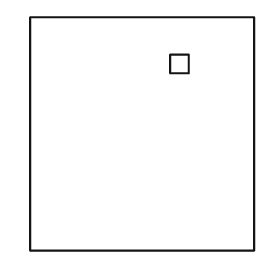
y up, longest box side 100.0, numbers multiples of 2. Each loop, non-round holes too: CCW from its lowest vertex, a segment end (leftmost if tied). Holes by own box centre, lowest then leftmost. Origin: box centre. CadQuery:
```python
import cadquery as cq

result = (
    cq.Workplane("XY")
    .moveTo(-48.0, -50.0)
    .lineTo(48.0, -50.0)
    .lineTo(48.0, 50.0)
    .lineTo(-48.0, 50.0)
    .close()
    .moveTo(12.0, 26.0)
    .lineTo(20.0, 26.0)
    .lineTo(20.0, 34.0)
    .lineTo(12.0, 34.0)
    .close()
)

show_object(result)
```